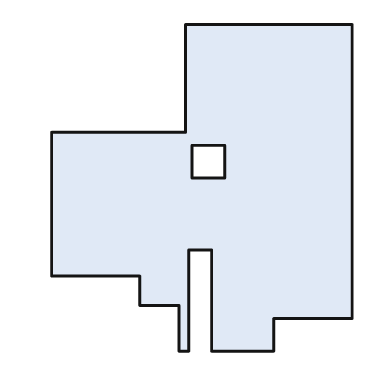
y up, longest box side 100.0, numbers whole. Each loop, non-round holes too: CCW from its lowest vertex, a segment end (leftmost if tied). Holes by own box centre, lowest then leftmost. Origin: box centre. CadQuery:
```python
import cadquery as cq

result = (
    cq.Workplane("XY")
    .moveTo(-7.0, -50.0)
    .lineTo(-4.0, -50.0)
    .lineTo(-4.0, -19.0)
    .lineTo(3.0, -19.0)
    .lineTo(3.0, -50.0)
    .lineTo(22.0, -50.0)
    .lineTo(22.0, -40.0)
    .lineTo(46.0, -40.0)
    .lineTo(46.0, 50.0)
    .lineTo(-5.0, 50.0)
    .lineTo(-5.0, 17.0)
    .lineTo(-46.0, 17.0)
    .lineTo(-46.0, -27.0)
    .lineTo(-19.0, -27.0)
    .lineTo(-19.0, -36.0)
    .lineTo(-7.0, -36.0)
    .close()
    .moveTo(-3.0, 3.0)
    .lineTo(7.0, 3.0)
    .lineTo(7.0, 13.0)
    .lineTo(-3.0, 13.0)
    .close()
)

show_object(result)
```